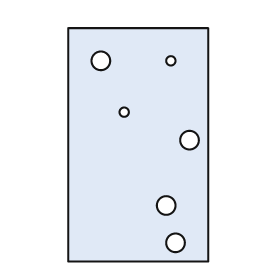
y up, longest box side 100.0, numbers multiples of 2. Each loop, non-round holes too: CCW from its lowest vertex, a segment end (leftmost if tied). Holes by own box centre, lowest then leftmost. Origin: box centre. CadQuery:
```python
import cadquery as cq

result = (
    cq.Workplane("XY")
    .moveTo(-30.0, -50.0)
    .lineTo(30.0, -50.0)
    .lineTo(30.0, 50.0)
    .lineTo(-30.0, 50.0)
    .close()
    .moveTo(16.0, -42.0)
    .circle(4.0)
    .moveTo(12.0, -26.0)
    .circle(4.0)
    .moveTo(22.0, 2.0)
    .circle(4.0)
    .moveTo(-6.0, 14.0)
    .circle(2.0)
    .moveTo(-16.0, 36.0)
    .circle(4.0)
    .moveTo(14.0, 36.0)
    .circle(2.0)
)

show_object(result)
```